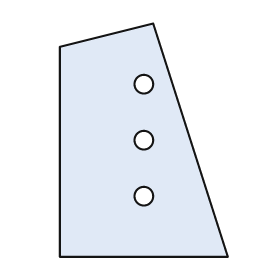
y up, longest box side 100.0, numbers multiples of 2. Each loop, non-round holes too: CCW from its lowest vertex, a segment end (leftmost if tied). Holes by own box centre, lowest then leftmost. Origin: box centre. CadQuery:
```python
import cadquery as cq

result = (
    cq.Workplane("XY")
    .moveTo(-36.0, -50.0)
    .lineTo(36.0, -50.0)
    .lineTo(4.0, 50.0)
    .lineTo(-36.0, 40.0)
    .close()
    .moveTo(0.0, -24.0)
    .circle(4.0)
    .moveTo(0.0, 0.0)
    .circle(4.0)
    .moveTo(0.0, 24.0)
    .circle(4.0)
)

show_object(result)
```